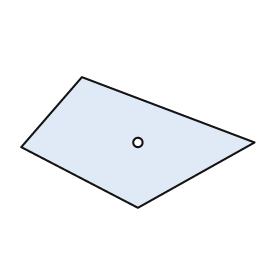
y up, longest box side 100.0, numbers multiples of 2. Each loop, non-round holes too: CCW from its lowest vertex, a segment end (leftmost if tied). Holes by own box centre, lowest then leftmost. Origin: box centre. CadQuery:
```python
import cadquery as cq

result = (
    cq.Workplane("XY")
    .moveTo(0.0, -28.0)
    .lineTo(50.0, 0.0)
    .lineTo(-24.0, 28.0)
    .lineTo(-50.0, -2.0)
    .close()
    .moveTo(0.0, 0.0)
    .circle(2.0)
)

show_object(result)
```